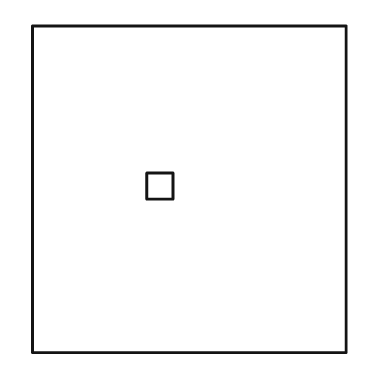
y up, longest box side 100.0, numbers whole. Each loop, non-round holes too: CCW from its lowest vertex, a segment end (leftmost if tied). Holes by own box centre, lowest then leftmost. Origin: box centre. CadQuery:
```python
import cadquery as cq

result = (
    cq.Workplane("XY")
    .moveTo(-48.0, -50.0)
    .lineTo(48.0, -50.0)
    .lineTo(48.0, 50.0)
    .lineTo(-48.0, 50.0)
    .close()
    .moveTo(-13.0, -3.0)
    .lineTo(-5.0, -3.0)
    .lineTo(-5.0, 5.0)
    .lineTo(-13.0, 5.0)
    .close()
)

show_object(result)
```